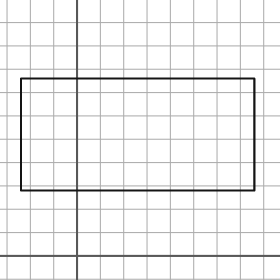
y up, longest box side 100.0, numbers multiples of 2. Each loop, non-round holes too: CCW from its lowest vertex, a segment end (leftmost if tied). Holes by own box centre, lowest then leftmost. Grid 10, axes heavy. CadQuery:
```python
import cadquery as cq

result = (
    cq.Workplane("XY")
    .moveTo(-24.0, 28.0)
    .lineTo(76.0, 28.0)
    .lineTo(76.0, 76.0)
    .lineTo(-24.0, 76.0)
    .close()
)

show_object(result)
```